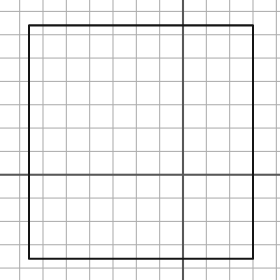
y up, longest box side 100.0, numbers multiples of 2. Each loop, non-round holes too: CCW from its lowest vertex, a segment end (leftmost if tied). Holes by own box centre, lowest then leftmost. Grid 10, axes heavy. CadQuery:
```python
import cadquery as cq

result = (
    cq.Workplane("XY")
    .moveTo(-66.0, -36.0)
    .lineTo(30.0, -36.0)
    .lineTo(30.0, 64.0)
    .lineTo(-66.0, 64.0)
    .close()
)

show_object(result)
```